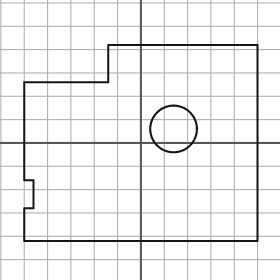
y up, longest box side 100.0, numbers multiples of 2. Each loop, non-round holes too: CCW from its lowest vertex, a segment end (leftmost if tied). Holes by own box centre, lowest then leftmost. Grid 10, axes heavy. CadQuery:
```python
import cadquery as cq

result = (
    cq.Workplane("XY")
    .moveTo(-50.0, -42.0)
    .lineTo(50.0, -42.0)
    .lineTo(50.0, 42.0)
    .lineTo(-14.0, 42.0)
    .lineTo(-14.0, 26.0)
    .lineTo(-50.0, 26.0)
    .lineTo(-50.0, -16.0)
    .lineTo(-46.0, -16.0)
    .lineTo(-46.0, -28.0)
    .lineTo(-50.0, -28.0)
    .close()
    .moveTo(14.0, 6.0)
    .circle(10.0)
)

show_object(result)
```